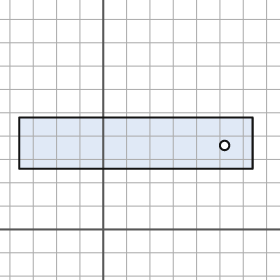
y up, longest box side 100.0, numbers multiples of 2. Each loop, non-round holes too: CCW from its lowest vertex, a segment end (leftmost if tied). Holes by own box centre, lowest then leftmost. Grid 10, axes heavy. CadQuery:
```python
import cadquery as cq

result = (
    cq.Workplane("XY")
    .moveTo(-36.0, 26.0)
    .lineTo(64.0, 26.0)
    .lineTo(64.0, 48.0)
    .lineTo(-36.0, 48.0)
    .close()
    .moveTo(52.0, 36.0)
    .circle(2.0)
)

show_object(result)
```